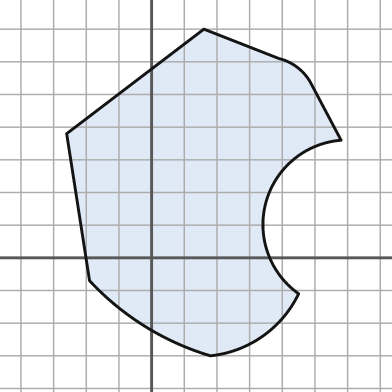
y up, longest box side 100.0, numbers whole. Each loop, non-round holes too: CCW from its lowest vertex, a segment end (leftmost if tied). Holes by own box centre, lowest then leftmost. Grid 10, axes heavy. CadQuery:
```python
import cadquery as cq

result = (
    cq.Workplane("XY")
    .moveTo(18.0, -30.0)
    .threePointArc((34.0, -24.0), (45.0, -11.0))
    .threePointArc((35.0, 17.0), (58.0, 36.0))
    .lineTo(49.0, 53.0)
    .threePointArc((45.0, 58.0), (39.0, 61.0))
    .lineTo(16.0, 70.0)
    .lineTo(-26.0, 38.0)
    .lineTo(-19.0, -7.0)
    .threePointArc((-2.0, -21.0), (18.0, -30.0))
    .close()
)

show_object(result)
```